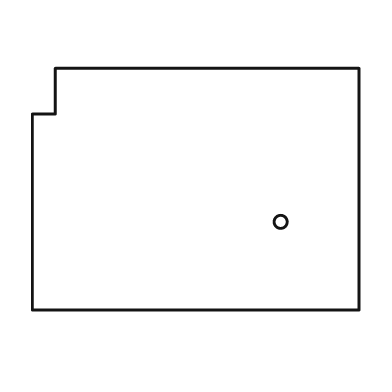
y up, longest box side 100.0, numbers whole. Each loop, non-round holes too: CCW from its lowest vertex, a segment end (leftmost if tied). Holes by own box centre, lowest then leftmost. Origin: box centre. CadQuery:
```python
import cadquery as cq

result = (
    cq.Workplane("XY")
    .moveTo(-50.0, -37.0)
    .lineTo(50.0, -37.0)
    .lineTo(50.0, 37.0)
    .lineTo(-43.0, 37.0)
    .lineTo(-43.0, 23.0)
    .lineTo(-50.0, 23.0)
    .close()
    .moveTo(26.0, -10.0)
    .circle(2.0)
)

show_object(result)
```